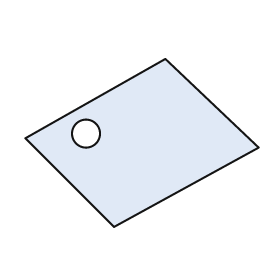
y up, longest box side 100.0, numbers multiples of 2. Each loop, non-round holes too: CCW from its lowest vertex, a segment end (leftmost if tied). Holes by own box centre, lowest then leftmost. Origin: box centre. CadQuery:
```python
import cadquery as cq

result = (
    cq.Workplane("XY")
    .moveTo(-12.0, -36.0)
    .lineTo(50.0, -2.0)
    .lineTo(10.0, 36.0)
    .lineTo(-50.0, 2.0)
    .close()
    .moveTo(-24.0, 4.0)
    .circle(6.0)
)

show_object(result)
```